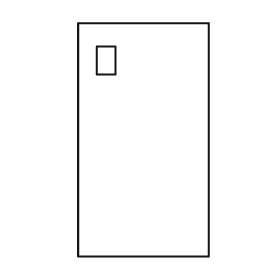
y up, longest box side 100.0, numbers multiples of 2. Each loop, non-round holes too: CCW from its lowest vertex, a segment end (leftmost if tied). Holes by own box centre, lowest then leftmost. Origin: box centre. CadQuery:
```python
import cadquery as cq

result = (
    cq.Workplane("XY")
    .moveTo(-28.0, -50.0)
    .lineTo(28.0, -50.0)
    .lineTo(28.0, 50.0)
    .lineTo(-28.0, 50.0)
    .close()
    .moveTo(-20.0, 28.0)
    .lineTo(-12.0, 28.0)
    .lineTo(-12.0, 40.0)
    .lineTo(-20.0, 40.0)
    .close()
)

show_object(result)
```